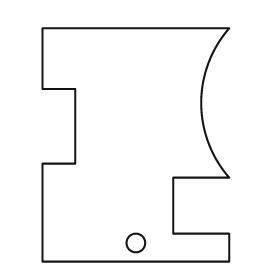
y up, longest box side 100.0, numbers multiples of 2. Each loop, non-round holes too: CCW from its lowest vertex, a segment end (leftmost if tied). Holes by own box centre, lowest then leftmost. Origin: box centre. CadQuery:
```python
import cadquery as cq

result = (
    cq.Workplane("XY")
    .moveTo(-40.0, -50.0)
    .lineTo(40.0, -50.0)
    .lineTo(40.0, -38.0)
    .lineTo(16.0, -38.0)
    .lineTo(16.0, -14.0)
    .lineTo(40.0, -14.0)
    .threePointArc((28.0, 18.0), (40.0, 50.0))
    .lineTo(-40.0, 50.0)
    .lineTo(-40.0, 24.0)
    .lineTo(-26.0, 24.0)
    .lineTo(-26.0, -8.0)
    .lineTo(-40.0, -8.0)
    .close()
    .moveTo(0.0, -42.0)
    .circle(4.0)
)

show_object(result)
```